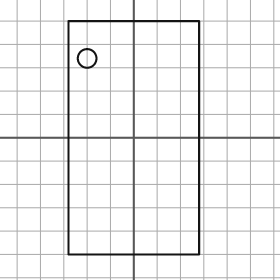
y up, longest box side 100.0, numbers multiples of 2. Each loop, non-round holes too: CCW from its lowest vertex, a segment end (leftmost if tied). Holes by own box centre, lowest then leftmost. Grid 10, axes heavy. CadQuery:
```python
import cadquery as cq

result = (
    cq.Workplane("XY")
    .moveTo(-28.0, -50.0)
    .lineTo(28.0, -50.0)
    .lineTo(28.0, 50.0)
    .lineTo(-28.0, 50.0)
    .close()
    .moveTo(-20.0, 34.0)
    .circle(4.0)
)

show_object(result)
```